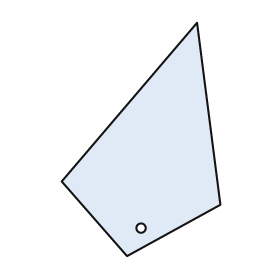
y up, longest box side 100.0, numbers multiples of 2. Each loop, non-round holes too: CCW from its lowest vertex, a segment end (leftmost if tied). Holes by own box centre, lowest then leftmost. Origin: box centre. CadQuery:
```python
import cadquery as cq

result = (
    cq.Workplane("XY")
    .moveTo(-6.0, -50.0)
    .lineTo(34.0, -28.0)
    .lineTo(24.0, 50.0)
    .lineTo(-34.0, -18.0)
    .close()
    .moveTo(0.0, -38.0)
    .circle(2.0)
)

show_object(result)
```